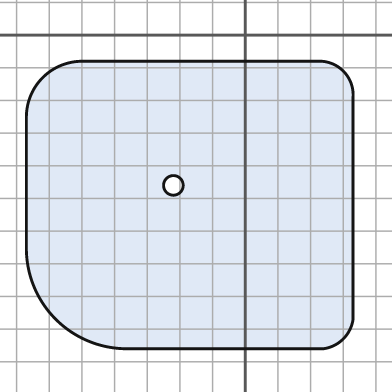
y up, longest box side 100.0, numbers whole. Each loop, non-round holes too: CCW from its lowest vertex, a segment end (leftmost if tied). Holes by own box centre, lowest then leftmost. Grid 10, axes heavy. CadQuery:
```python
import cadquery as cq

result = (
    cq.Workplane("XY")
    .moveTo(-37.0, -96.0)
    .lineTo(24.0, -96.0)
    .threePointArc((30.0, -93.0), (33.0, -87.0))
    .lineTo(33.0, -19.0)
    .threePointArc((30.0, -11.0), (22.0, -8.0))
    .lineTo(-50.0, -8.0)
    .threePointArc((-62.0, -13.0), (-67.0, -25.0))
    .lineTo(-67.0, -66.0)
    .threePointArc((-58.0, -87.0), (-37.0, -96.0))
    .close()
    .moveTo(-22.0, -46.0)
    .circle(3.0)
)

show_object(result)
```